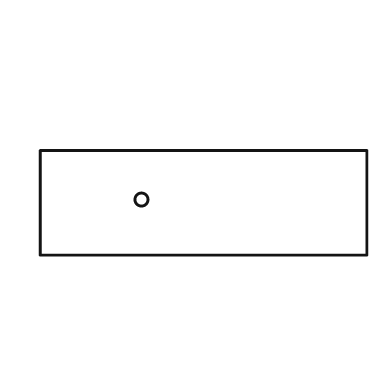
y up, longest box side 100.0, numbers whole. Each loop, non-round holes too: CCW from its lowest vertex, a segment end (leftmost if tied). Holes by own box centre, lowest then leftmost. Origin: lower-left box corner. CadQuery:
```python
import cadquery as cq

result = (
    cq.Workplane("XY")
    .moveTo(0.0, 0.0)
    .lineTo(100.0, 0.0)
    .lineTo(100.0, 32.0)
    .lineTo(0.0, 32.0)
    .close()
    .moveTo(31.0, 17.0)
    .circle(2.0)
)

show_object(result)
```